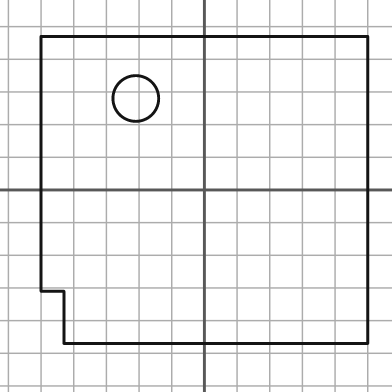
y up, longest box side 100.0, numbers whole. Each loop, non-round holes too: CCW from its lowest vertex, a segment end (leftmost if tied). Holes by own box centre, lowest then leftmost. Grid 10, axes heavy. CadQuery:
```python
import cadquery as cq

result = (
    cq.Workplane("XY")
    .moveTo(-43.0, -47.0)
    .lineTo(50.0, -47.0)
    .lineTo(50.0, 47.0)
    .lineTo(-50.0, 47.0)
    .lineTo(-50.0, -31.0)
    .lineTo(-43.0, -31.0)
    .close()
    .moveTo(-21.0, 28.0)
    .circle(7.0)
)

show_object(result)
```